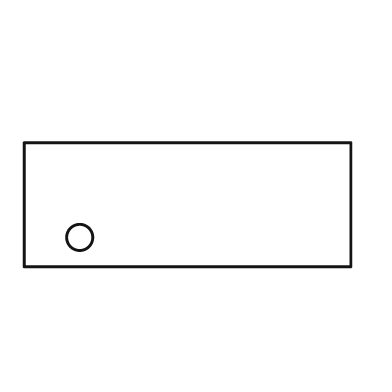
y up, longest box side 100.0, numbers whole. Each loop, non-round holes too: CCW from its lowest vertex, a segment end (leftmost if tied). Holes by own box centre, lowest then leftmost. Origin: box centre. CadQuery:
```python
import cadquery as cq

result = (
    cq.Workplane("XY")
    .moveTo(-50.0, -19.0)
    .lineTo(50.0, -19.0)
    .lineTo(50.0, 19.0)
    .lineTo(-50.0, 19.0)
    .close()
    .moveTo(-33.0, -10.0)
    .circle(4.0)
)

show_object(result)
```